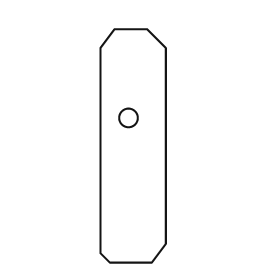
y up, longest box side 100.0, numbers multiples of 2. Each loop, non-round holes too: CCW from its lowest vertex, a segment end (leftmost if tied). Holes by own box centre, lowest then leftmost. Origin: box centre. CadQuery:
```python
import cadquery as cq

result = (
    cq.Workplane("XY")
    .moveTo(-10.0, -50.0)
    .lineTo(8.0, -50.0)
    .lineTo(14.0, -42.0)
    .lineTo(14.0, 42.0)
    .lineTo(6.0, 50.0)
    .lineTo(-8.0, 50.0)
    .lineTo(-14.0, 42.0)
    .lineTo(-14.0, -46.0)
    .close()
    .moveTo(-2.0, 12.0)
    .circle(4.0)
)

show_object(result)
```